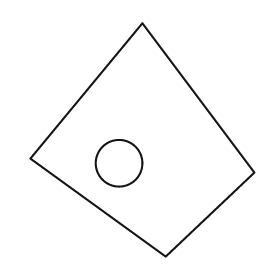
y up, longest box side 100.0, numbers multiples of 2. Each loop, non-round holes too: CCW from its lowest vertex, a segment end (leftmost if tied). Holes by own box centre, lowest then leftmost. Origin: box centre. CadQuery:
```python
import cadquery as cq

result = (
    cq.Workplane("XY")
    .moveTo(10.0, -50.0)
    .lineTo(48.0, -14.0)
    .lineTo(0.0, 50.0)
    .lineTo(-48.0, -8.0)
    .close()
    .moveTo(-10.0, -10.0)
    .circle(10.0)
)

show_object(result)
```